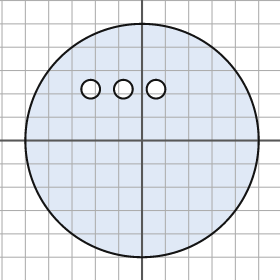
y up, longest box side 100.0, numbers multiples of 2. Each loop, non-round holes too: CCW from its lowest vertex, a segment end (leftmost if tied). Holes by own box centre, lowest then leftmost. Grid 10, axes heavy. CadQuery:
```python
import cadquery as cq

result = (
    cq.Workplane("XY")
    .moveTo(0.0, 0.0)
    .circle(50.0)
    .moveTo(-22.0, 22.0)
    .circle(4.0)
    .moveTo(-8.0, 22.0)
    .circle(4.0)
    .moveTo(6.0, 22.0)
    .circle(4.0)
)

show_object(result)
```